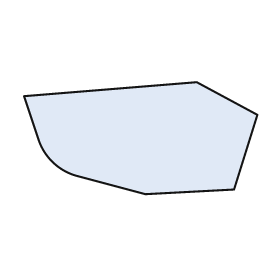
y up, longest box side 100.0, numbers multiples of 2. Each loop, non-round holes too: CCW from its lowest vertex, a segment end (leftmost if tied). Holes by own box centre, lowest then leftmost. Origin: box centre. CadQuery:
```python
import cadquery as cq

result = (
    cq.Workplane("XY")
    .moveTo(2.0, -24.0)
    .lineTo(40.0, -22.0)
    .lineTo(50.0, 10.0)
    .lineTo(24.0, 24.0)
    .lineTo(-50.0, 18.0)
    .lineTo(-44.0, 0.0)
    .threePointArc((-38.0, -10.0), (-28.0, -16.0))
    .close()
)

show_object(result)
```